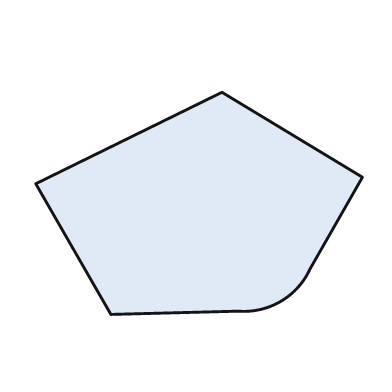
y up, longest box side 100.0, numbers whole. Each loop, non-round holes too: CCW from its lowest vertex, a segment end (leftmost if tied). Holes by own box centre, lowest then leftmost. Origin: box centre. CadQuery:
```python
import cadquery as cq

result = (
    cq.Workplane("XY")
    .moveTo(-27.0, -34.0)
    .lineTo(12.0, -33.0)
    .threePointArc((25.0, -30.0), (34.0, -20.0))
    .lineTo(50.0, 8.0)
    .lineTo(7.0, 34.0)
    .lineTo(-50.0, 6.0)
    .close()
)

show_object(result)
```